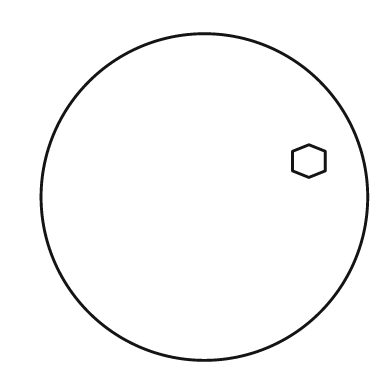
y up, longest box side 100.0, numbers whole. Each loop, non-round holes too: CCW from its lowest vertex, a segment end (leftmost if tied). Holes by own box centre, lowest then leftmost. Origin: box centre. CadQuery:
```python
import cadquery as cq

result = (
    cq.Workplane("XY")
    .moveTo(0.0, 0.0)
    .circle(50.0)
    .moveTo(32.0, 6.0)
    .lineTo(37.0, 8.0)
    .lineTo(37.0, 14.0)
    .lineTo(32.0, 16.0)
    .lineTo(27.0, 14.0)
    .lineTo(27.0, 8.0)
    .close()
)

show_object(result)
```